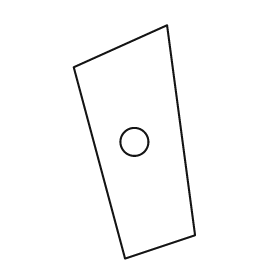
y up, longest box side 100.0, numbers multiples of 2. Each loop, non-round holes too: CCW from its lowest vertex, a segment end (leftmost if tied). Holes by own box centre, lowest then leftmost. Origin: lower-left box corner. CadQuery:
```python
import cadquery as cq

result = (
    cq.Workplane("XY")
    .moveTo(22.0, 0.0)
    .lineTo(52.0, 10.0)
    .lineTo(40.0, 100.0)
    .lineTo(0.0, 82.0)
    .close()
    .moveTo(26.0, 50.0)
    .circle(6.0)
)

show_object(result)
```